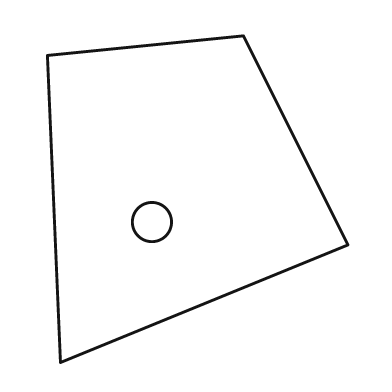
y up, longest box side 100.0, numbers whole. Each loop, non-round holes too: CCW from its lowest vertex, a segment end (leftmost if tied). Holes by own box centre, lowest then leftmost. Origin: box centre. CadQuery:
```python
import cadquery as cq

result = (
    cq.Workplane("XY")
    .moveTo(-42.0, -50.0)
    .lineTo(46.0, -14.0)
    .lineTo(14.0, 50.0)
    .lineTo(-46.0, 44.0)
    .close()
    .moveTo(-14.0, -7.0)
    .circle(6.0)
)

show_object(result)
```